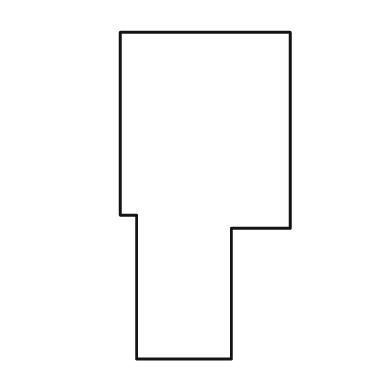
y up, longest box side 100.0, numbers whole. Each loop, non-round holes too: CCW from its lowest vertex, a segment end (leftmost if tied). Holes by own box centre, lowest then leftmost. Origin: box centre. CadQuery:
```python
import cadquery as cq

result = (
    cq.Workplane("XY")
    .moveTo(-21.0, -50.0)
    .lineTo(8.0, -50.0)
    .lineTo(8.0, -10.0)
    .lineTo(26.0, -10.0)
    .lineTo(26.0, 50.0)
    .lineTo(-26.0, 50.0)
    .lineTo(-26.0, -6.0)
    .lineTo(-21.0, -6.0)
    .close()
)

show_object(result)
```